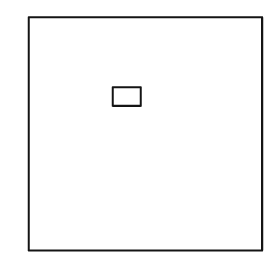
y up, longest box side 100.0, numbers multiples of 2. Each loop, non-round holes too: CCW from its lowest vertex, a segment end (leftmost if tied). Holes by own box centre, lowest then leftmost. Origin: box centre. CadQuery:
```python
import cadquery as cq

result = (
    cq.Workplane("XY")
    .moveTo(-50.0, -50.0)
    .lineTo(50.0, -50.0)
    .lineTo(50.0, 50.0)
    .lineTo(-50.0, 50.0)
    .close()
    .moveTo(-14.0, 12.0)
    .lineTo(-2.0, 12.0)
    .lineTo(-2.0, 20.0)
    .lineTo(-14.0, 20.0)
    .close()
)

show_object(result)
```